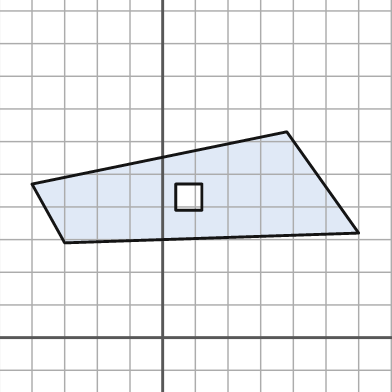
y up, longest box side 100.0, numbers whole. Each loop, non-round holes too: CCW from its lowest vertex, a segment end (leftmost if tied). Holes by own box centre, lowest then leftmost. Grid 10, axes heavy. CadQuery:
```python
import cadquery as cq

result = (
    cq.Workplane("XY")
    .moveTo(-30.0, 29.0)
    .lineTo(60.0, 32.0)
    .lineTo(38.0, 63.0)
    .lineTo(-40.0, 47.0)
    .close()
    .moveTo(4.0, 39.0)
    .lineTo(12.0, 39.0)
    .lineTo(12.0, 47.0)
    .lineTo(4.0, 47.0)
    .close()
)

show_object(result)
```